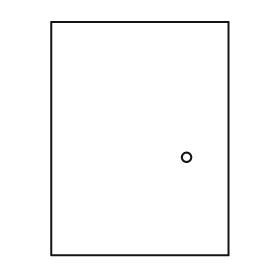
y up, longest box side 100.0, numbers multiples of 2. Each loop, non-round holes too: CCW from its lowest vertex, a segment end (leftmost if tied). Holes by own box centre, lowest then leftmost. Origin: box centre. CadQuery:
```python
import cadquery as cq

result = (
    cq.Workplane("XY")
    .moveTo(-38.0, -50.0)
    .lineTo(38.0, -50.0)
    .lineTo(38.0, 50.0)
    .lineTo(-38.0, 50.0)
    .close()
    .moveTo(20.0, -8.0)
    .circle(2.0)
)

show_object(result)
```